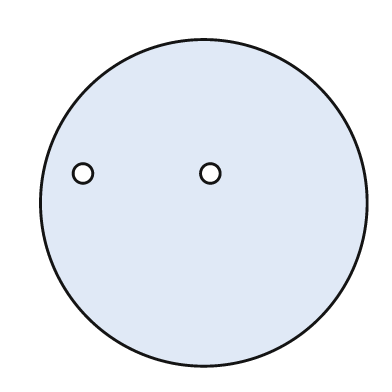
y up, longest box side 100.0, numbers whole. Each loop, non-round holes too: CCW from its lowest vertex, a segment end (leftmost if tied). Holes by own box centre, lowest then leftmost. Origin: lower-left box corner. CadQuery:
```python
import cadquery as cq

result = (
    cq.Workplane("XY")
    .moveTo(50.0, 50.0)
    .circle(50.0)
    .moveTo(13.0, 59.0)
    .circle(3.0)
    .moveTo(52.0, 59.0)
    .circle(3.0)
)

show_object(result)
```